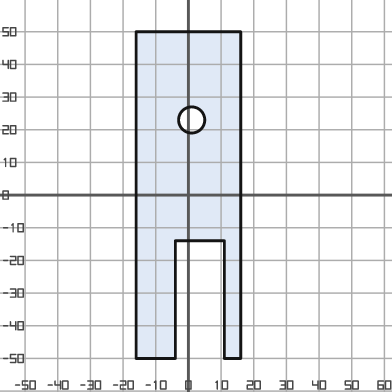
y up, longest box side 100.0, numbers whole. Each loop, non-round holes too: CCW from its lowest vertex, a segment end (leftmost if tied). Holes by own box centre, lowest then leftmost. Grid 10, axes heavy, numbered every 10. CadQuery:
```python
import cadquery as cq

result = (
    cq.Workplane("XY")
    .moveTo(-16.0, -50.0)
    .lineTo(-4.0, -50.0)
    .lineTo(-4.0, -14.0)
    .lineTo(11.0, -14.0)
    .lineTo(11.0, -50.0)
    .lineTo(16.0, -50.0)
    .lineTo(16.0, 50.0)
    .lineTo(-16.0, 50.0)
    .close()
    .moveTo(1.0, 23.0)
    .circle(4.0)
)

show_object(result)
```